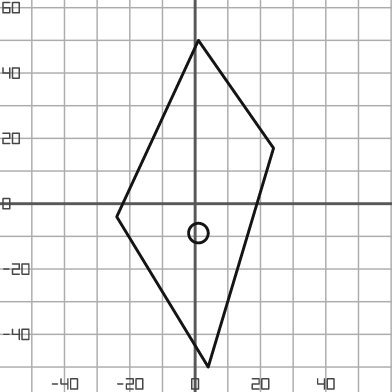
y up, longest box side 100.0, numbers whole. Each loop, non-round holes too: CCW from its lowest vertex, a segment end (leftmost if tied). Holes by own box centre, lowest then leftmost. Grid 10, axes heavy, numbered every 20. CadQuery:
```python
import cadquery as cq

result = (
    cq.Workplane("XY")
    .moveTo(4.0, -50.0)
    .lineTo(24.0, 17.0)
    .lineTo(1.0, 50.0)
    .lineTo(-24.0, -4.0)
    .close()
    .moveTo(1.0, -9.0)
    .circle(3.0)
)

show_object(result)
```